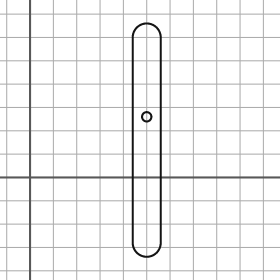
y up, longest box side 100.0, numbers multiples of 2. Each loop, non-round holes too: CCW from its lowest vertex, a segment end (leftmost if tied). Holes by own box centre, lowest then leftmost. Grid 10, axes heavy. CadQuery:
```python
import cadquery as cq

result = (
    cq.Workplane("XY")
    .moveTo(44.0, -28.0)
    .threePointArc((50.0, -34.0), (56.0, -28.0))
    .lineTo(56.0, 60.0)
    .threePointArc((50.0, 66.0), (44.0, 60.0))
    .close()
    .moveTo(50.0, 26.0)
    .circle(2.0)
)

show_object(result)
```